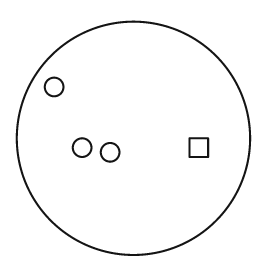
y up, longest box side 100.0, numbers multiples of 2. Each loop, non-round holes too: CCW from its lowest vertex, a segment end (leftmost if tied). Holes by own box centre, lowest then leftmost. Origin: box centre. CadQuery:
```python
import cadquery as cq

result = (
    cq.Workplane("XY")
    .moveTo(0.0, 0.0)
    .circle(50.0)
    .moveTo(-10.0, -6.0)
    .circle(4.0)
    .moveTo(-22.0, -4.0)
    .circle(4.0)
    .moveTo(24.0, -8.0)
    .lineTo(32.0, -8.0)
    .lineTo(32.0, 0.0)
    .lineTo(24.0, 0.0)
    .close()
    .moveTo(-34.0, 22.0)
    .circle(4.0)
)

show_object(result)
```